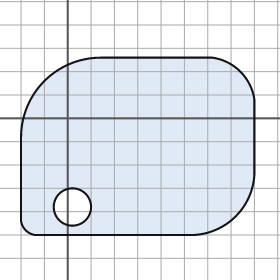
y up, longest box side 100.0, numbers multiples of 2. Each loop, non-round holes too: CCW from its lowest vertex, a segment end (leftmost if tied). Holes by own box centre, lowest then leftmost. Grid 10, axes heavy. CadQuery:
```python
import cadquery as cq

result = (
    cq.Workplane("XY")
    .moveTo(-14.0, -50.0)
    .lineTo(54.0, -50.0)
    .threePointArc((72.0, -42.0), (80.0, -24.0))
    .lineTo(80.0, 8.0)
    .threePointArc((74.0, 20.0), (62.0, 26.0))
    .lineTo(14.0, 26.0)
    .threePointArc((-10.0, 16.0), (-20.0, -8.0))
    .lineTo(-20.0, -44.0)
    .threePointArc((-18.0, -48.0), (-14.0, -50.0))
    .close()
    .moveTo(2.0, -38.0)
    .circle(8.0)
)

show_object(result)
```